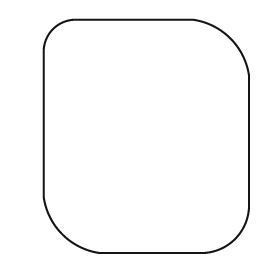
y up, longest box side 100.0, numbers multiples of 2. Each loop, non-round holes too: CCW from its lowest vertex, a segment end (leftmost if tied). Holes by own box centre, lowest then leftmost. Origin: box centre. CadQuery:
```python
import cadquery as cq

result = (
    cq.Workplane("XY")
    .moveTo(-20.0, -50.0)
    .lineTo(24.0, -50.0)
    .threePointArc((38.0, -44.0), (44.0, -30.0))
    .lineTo(44.0, 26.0)
    .threePointArc((36.0, 42.0), (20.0, 50.0))
    .lineTo(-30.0, 50.0)
    .threePointArc((-40.0, 46.0), (-44.0, 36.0))
    .lineTo(-44.0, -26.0)
    .threePointArc((-36.0, -42.0), (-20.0, -50.0))
    .close()
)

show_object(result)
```